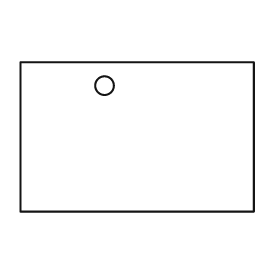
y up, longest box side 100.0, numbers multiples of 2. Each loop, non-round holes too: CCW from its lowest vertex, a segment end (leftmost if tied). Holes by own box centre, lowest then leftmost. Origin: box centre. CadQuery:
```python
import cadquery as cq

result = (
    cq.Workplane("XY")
    .moveTo(-50.0, -32.0)
    .lineTo(50.0, -32.0)
    .lineTo(50.0, 32.0)
    .lineTo(-50.0, 32.0)
    .close()
    .moveTo(-14.0, 22.0)
    .circle(4.0)
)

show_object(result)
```